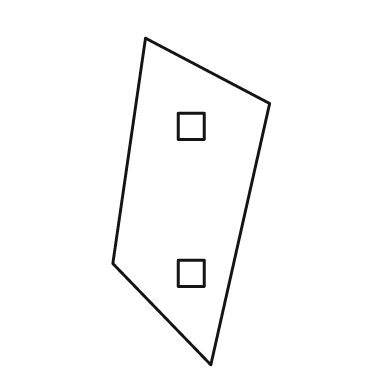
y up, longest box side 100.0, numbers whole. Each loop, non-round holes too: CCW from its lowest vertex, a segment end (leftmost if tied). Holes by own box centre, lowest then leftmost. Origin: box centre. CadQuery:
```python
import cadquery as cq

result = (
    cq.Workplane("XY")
    .moveTo(6.0, -50.0)
    .lineTo(24.0, 30.0)
    .lineTo(-14.0, 50.0)
    .lineTo(-24.0, -19.0)
    .close()
    .moveTo(-4.0, -26.0)
    .lineTo(4.0, -26.0)
    .lineTo(4.0, -18.0)
    .lineTo(-4.0, -18.0)
    .close()
    .moveTo(-4.0, 19.0)
    .lineTo(4.0, 19.0)
    .lineTo(4.0, 27.0)
    .lineTo(-4.0, 27.0)
    .close()
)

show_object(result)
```